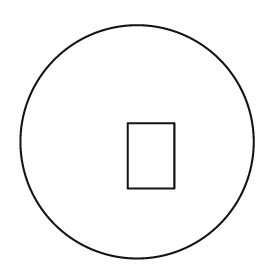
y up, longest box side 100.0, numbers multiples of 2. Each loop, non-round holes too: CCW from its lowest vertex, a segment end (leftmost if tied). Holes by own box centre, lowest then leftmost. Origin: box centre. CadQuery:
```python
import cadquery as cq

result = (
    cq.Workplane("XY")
    .moveTo(0.0, 0.0)
    .circle(50.0)
    .moveTo(-4.0, -20.0)
    .lineTo(16.0, -20.0)
    .lineTo(16.0, 8.0)
    .lineTo(-4.0, 8.0)
    .close()
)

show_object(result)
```